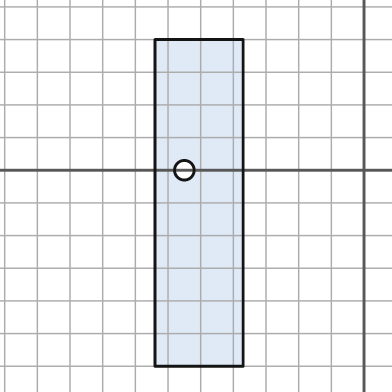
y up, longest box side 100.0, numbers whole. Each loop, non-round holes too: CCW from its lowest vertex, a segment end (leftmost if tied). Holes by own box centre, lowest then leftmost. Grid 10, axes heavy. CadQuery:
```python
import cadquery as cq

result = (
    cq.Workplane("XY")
    .moveTo(-64.0, -60.0)
    .lineTo(-37.0, -60.0)
    .lineTo(-37.0, 40.0)
    .lineTo(-64.0, 40.0)
    .close()
    .moveTo(-55.0, 0.0)
    .circle(3.0)
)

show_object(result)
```